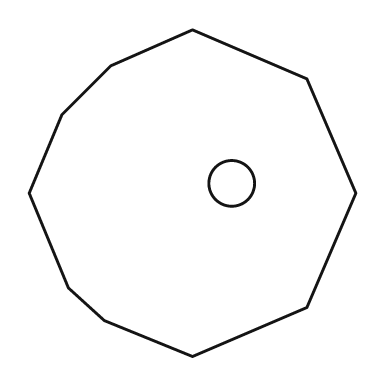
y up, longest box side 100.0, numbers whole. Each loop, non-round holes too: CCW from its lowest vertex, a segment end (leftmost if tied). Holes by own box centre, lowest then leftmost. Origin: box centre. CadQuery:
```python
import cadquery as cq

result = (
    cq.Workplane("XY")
    .moveTo(0.0, -50.0)
    .lineTo(35.0, -35.0)
    .lineTo(50.0, 0.0)
    .lineTo(35.0, 35.0)
    .lineTo(0.0, 50.0)
    .lineTo(-25.0, 39.0)
    .lineTo(-40.0, 24.0)
    .lineTo(-50.0, 0.0)
    .lineTo(-38.0, -29.0)
    .lineTo(-27.0, -39.0)
    .close()
    .moveTo(12.0, 3.0)
    .circle(7.0)
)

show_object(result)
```